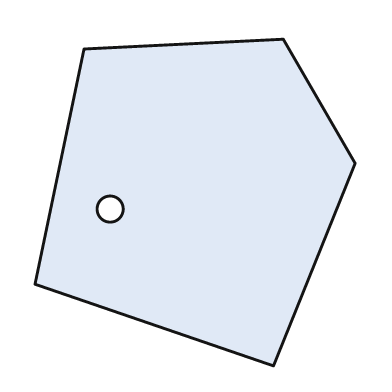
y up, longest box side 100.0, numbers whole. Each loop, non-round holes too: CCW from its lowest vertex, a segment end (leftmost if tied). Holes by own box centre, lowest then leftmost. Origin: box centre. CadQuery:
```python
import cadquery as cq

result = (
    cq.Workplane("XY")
    .moveTo(24.0, -50.0)
    .lineTo(49.0, 12.0)
    .lineTo(27.0, 50.0)
    .lineTo(-34.0, 47.0)
    .lineTo(-49.0, -25.0)
    .close()
    .moveTo(-26.0, -2.0)
    .circle(4.0)
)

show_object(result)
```